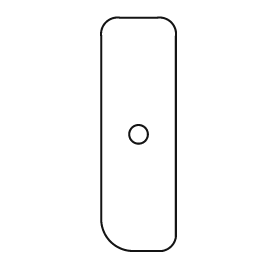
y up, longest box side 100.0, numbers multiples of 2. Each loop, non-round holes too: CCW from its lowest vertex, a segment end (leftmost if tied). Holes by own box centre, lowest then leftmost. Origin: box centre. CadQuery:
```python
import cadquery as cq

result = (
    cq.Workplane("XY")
    .moveTo(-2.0, -50.0)
    .lineTo(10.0, -50.0)
    .threePointArc((14.0, -48.0), (16.0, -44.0))
    .lineTo(16.0, 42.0)
    .threePointArc((14.0, 48.0), (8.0, 50.0))
    .lineTo(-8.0, 50.0)
    .threePointArc((-14.0, 48.0), (-16.0, 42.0))
    .lineTo(-16.0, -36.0)
    .threePointArc((-12.0, -46.0), (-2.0, -50.0))
    .close()
    .moveTo(0.0, 0.0)
    .circle(4.0)
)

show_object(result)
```